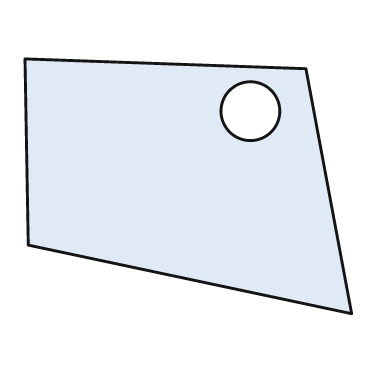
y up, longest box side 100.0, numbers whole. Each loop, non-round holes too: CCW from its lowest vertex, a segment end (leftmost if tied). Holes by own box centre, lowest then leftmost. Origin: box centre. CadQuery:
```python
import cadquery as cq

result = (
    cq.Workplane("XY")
    .moveTo(50.0, -39.0)
    .lineTo(36.0, 36.0)
    .lineTo(-50.0, 39.0)
    .lineTo(-49.0, -18.0)
    .close()
    .moveTo(19.0, 23.0)
    .circle(9.0)
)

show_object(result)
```